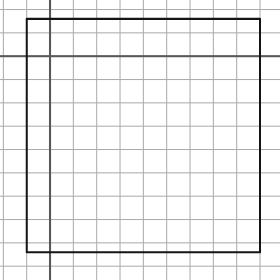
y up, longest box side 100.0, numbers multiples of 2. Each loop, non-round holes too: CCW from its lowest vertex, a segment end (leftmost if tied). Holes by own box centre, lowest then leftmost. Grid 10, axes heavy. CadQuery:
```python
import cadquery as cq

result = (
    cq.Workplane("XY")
    .moveTo(-10.0, -84.0)
    .lineTo(90.0, -84.0)
    .lineTo(90.0, 16.0)
    .lineTo(-10.0, 16.0)
    .close()
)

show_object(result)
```